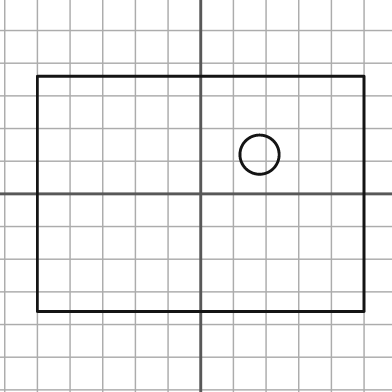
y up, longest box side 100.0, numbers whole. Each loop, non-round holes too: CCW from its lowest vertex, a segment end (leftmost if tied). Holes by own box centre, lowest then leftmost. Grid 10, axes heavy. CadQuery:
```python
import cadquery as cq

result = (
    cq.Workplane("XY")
    .moveTo(-50.0, -36.0)
    .lineTo(50.0, -36.0)
    .lineTo(50.0, 36.0)
    .lineTo(-50.0, 36.0)
    .close()
    .moveTo(18.0, 12.0)
    .circle(6.0)
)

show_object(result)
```